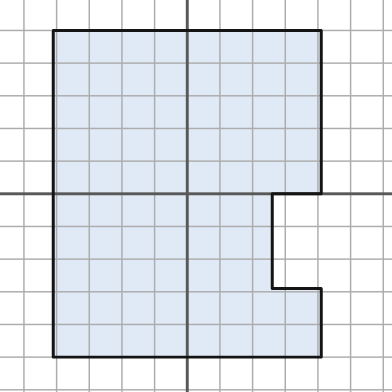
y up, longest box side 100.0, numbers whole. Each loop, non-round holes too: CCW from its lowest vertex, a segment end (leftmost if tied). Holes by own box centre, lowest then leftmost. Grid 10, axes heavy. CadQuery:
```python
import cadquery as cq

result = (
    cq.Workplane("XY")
    .moveTo(-41.0, -50.0)
    .lineTo(41.0, -50.0)
    .lineTo(41.0, -29.0)
    .lineTo(26.0, -29.0)
    .lineTo(26.0, 0.0)
    .lineTo(41.0, 0.0)
    .lineTo(41.0, 50.0)
    .lineTo(-41.0, 50.0)
    .close()
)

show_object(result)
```